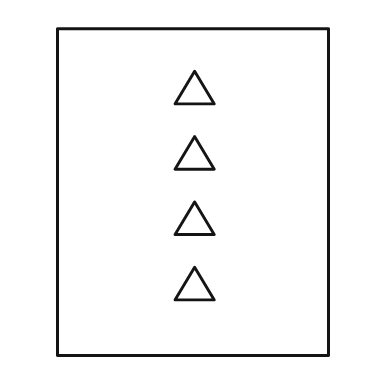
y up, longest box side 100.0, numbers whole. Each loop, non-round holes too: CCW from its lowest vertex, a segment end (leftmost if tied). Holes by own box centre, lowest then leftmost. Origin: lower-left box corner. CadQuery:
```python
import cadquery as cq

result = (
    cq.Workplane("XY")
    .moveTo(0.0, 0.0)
    .lineTo(83.0, 0.0)
    .lineTo(83.0, 100.0)
    .lineTo(0.0, 100.0)
    .close()
    .moveTo(36.0, 17.0)
    .lineTo(48.0, 17.0)
    .lineTo(42.0, 27.0)
    .close()
    .moveTo(36.0, 37.0)
    .lineTo(48.0, 37.0)
    .lineTo(42.0, 47.0)
    .close()
    .moveTo(36.0, 57.0)
    .lineTo(48.0, 57.0)
    .lineTo(42.0, 67.0)
    .close()
    .moveTo(36.0, 77.0)
    .lineTo(48.0, 77.0)
    .lineTo(42.0, 87.0)
    .close()
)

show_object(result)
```